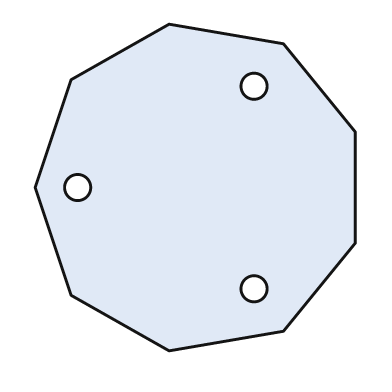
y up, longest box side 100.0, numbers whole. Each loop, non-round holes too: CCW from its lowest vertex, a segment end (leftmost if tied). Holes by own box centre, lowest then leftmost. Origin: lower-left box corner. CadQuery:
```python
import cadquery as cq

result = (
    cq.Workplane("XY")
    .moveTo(41.0, 0.0)
    .lineTo(76.0, 6.0)
    .lineTo(98.0, 33.0)
    .lineTo(98.0, 67.0)
    .lineTo(76.0, 94.0)
    .lineTo(41.0, 100.0)
    .lineTo(11.0, 83.0)
    .lineTo(0.0, 50.0)
    .lineTo(11.0, 17.0)
    .close()
    .moveTo(67.0, 19.0)
    .circle(4.0)
    .moveTo(13.0, 50.0)
    .circle(4.0)
    .moveTo(67.0, 81.0)
    .circle(4.0)
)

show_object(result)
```